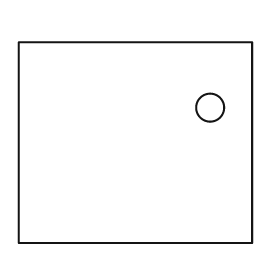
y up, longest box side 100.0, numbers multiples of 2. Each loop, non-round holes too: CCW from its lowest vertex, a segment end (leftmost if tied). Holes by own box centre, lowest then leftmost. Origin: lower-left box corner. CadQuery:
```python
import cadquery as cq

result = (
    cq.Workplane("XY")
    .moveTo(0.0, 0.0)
    .lineTo(100.0, 0.0)
    .lineTo(100.0, 86.0)
    .lineTo(0.0, 86.0)
    .close()
    .moveTo(82.0, 58.0)
    .circle(6.0)
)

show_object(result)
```